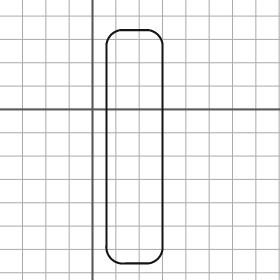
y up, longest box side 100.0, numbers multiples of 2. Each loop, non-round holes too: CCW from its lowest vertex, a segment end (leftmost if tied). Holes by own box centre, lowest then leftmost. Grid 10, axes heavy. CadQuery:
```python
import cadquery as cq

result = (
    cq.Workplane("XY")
    .moveTo(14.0, -66.0)
    .lineTo(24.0, -66.0)
    .threePointArc((28.0, -64.0), (30.0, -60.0))
    .lineTo(30.0, 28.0)
    .threePointArc((28.0, 32.0), (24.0, 34.0))
    .lineTo(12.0, 34.0)
    .threePointArc((8.0, 32.0), (6.0, 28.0))
    .lineTo(6.0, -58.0)
    .threePointArc((8.0, -64.0), (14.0, -66.0))
    .close()
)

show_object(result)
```